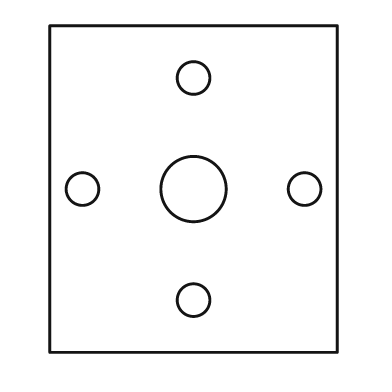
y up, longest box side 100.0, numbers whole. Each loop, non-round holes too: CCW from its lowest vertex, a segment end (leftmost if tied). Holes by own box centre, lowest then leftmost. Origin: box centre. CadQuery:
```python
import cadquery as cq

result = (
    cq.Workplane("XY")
    .moveTo(-44.0, -50.0)
    .lineTo(44.0, -50.0)
    .lineTo(44.0, 50.0)
    .lineTo(-44.0, 50.0)
    .close()
    .moveTo(0.0, -34.0)
    .circle(5.0)
    .moveTo(-34.0, 0.0)
    .circle(5.0)
    .moveTo(0.0, 0.0)
    .circle(10.0)
    .moveTo(34.0, 0.0)
    .circle(5.0)
    .moveTo(0.0, 34.0)
    .circle(5.0)
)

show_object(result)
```